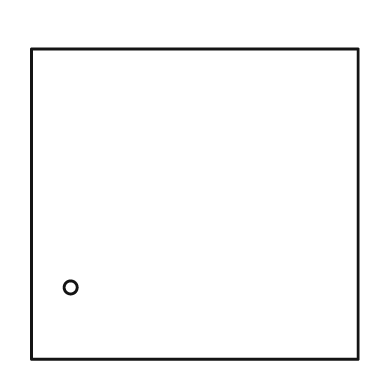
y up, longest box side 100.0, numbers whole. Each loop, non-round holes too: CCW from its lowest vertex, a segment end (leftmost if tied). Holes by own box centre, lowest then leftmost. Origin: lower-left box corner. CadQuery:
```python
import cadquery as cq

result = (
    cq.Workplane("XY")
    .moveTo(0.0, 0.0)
    .lineTo(100.0, 0.0)
    .lineTo(100.0, 95.0)
    .lineTo(0.0, 95.0)
    .close()
    .moveTo(12.0, 22.0)
    .circle(2.0)
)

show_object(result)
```